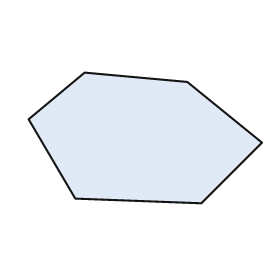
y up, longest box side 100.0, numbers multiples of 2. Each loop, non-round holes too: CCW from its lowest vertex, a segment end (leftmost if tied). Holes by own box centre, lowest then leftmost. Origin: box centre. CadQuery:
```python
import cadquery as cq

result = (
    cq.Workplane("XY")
    .moveTo(24.0, -28.0)
    .lineTo(50.0, -2.0)
    .lineTo(18.0, 24.0)
    .lineTo(-26.0, 28.0)
    .lineTo(-50.0, 8.0)
    .lineTo(-30.0, -26.0)
    .close()
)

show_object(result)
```